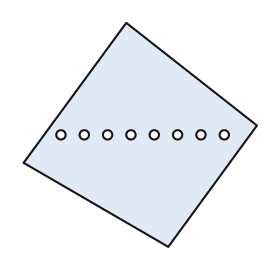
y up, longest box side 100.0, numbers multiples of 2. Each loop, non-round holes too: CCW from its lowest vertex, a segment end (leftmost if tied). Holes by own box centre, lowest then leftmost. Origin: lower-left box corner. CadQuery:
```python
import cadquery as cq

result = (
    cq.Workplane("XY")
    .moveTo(62.0, 0.0)
    .lineTo(100.0, 52.0)
    .lineTo(44.0, 96.0)
    .lineTo(0.0, 36.0)
    .close()
    .moveTo(16.0, 48.0)
    .circle(2.0)
    .moveTo(26.0, 48.0)
    .circle(2.0)
    .moveTo(36.0, 48.0)
    .circle(2.0)
    .moveTo(46.0, 48.0)
    .circle(2.0)
    .moveTo(56.0, 48.0)
    .circle(2.0)
    .moveTo(66.0, 48.0)
    .circle(2.0)
    .moveTo(76.0, 48.0)
    .circle(2.0)
    .moveTo(86.0, 48.0)
    .circle(2.0)
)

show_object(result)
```